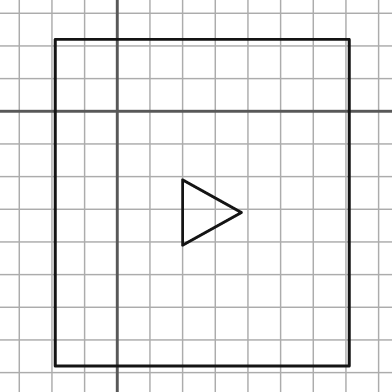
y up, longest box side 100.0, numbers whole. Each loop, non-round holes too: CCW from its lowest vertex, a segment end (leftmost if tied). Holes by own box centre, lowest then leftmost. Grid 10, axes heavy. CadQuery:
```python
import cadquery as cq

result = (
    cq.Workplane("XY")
    .moveTo(-19.0, -78.0)
    .lineTo(71.0, -78.0)
    .lineTo(71.0, 22.0)
    .lineTo(-19.0, 22.0)
    .close()
    .moveTo(20.0, -41.0)
    .lineTo(38.0, -31.0)
    .lineTo(20.0, -21.0)
    .close()
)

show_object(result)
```